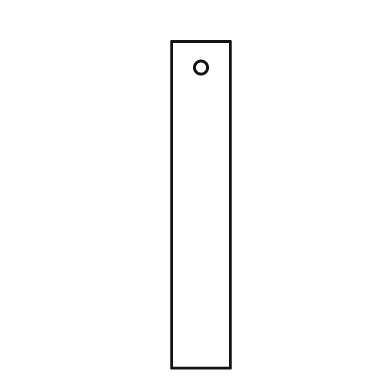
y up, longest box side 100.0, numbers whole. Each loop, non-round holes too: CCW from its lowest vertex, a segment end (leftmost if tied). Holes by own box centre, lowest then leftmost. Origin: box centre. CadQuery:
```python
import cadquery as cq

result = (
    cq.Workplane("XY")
    .moveTo(-9.0, -50.0)
    .lineTo(9.0, -50.0)
    .lineTo(9.0, 50.0)
    .lineTo(-9.0, 50.0)
    .close()
    .moveTo(0.0, 42.0)
    .circle(2.0)
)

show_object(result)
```